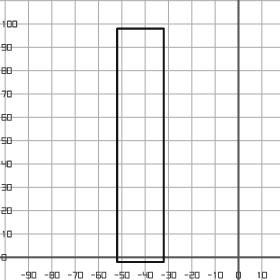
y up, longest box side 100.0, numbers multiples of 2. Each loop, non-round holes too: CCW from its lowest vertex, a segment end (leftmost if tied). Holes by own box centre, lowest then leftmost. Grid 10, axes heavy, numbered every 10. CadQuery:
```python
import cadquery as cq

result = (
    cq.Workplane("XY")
    .moveTo(-52.0, -2.0)
    .lineTo(-32.0, -2.0)
    .lineTo(-32.0, 98.0)
    .lineTo(-52.0, 98.0)
    .close()
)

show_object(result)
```